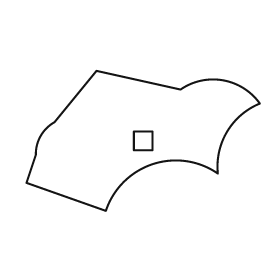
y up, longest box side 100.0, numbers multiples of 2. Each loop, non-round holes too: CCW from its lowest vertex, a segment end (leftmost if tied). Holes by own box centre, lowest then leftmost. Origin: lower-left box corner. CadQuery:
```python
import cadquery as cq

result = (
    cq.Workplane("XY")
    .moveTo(34.0, 0.0)
    .threePointArc((54.0, 20.0), (82.0, 16.0))
    .threePointArc((86.0, 34.0), (100.0, 46.0))
    .threePointArc((84.0, 56.0), (66.0, 52.0))
    .lineTo(30.0, 60.0)
    .lineTo(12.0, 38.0)
    .threePointArc((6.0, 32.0), (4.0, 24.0))
    .lineTo(0.0, 12.0)
    .close()
    .moveTo(46.0, 26.0)
    .lineTo(54.0, 26.0)
    .lineTo(54.0, 34.0)
    .lineTo(46.0, 34.0)
    .close()
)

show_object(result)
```